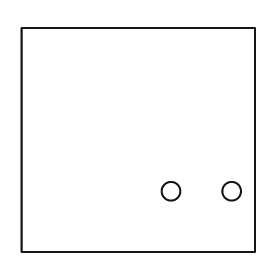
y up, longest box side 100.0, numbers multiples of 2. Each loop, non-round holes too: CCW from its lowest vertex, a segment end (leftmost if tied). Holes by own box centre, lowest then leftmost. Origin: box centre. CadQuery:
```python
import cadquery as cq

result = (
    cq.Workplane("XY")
    .moveTo(-50.0, -48.0)
    .lineTo(50.0, -48.0)
    .lineTo(50.0, 48.0)
    .lineTo(-50.0, 48.0)
    .close()
    .moveTo(14.0, -22.0)
    .circle(4.0)
    .moveTo(40.0, -22.0)
    .circle(4.0)
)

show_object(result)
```